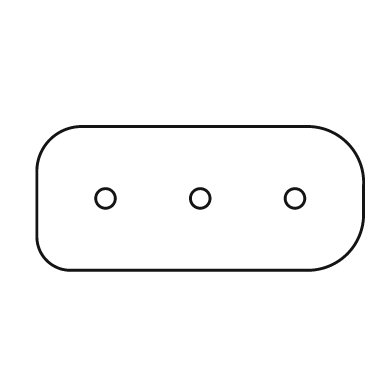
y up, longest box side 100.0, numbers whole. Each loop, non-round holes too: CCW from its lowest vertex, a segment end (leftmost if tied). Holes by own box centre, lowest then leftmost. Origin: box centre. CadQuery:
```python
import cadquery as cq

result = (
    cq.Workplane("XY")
    .moveTo(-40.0, -22.0)
    .lineTo(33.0, -22.0)
    .threePointArc((45.0, -17.0), (50.0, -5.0))
    .lineTo(50.0, 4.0)
    .threePointArc((45.0, 17.0), (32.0, 22.0))
    .lineTo(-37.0, 22.0)
    .threePointArc((-46.0, 18.0), (-50.0, 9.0))
    .lineTo(-50.0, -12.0)
    .threePointArc((-47.0, -19.0), (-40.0, -22.0))
    .close()
    .moveTo(-29.0, 0.0)
    .circle(3.0)
    .moveTo(0.0, 0.0)
    .circle(3.0)
    .moveTo(29.0, 0.0)
    .circle(3.0)
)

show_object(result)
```